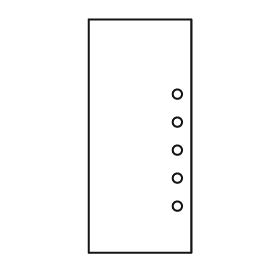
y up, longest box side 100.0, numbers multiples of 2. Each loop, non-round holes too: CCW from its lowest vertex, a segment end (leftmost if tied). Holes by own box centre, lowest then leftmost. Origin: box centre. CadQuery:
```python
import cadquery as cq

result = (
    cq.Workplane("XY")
    .moveTo(-22.0, -50.0)
    .lineTo(22.0, -50.0)
    .lineTo(22.0, 50.0)
    .lineTo(-22.0, 50.0)
    .close()
    .moveTo(16.0, -30.0)
    .circle(2.0)
    .moveTo(16.0, -18.0)
    .circle(2.0)
    .moveTo(16.0, -6.0)
    .circle(2.0)
    .moveTo(16.0, 6.0)
    .circle(2.0)
    .moveTo(16.0, 18.0)
    .circle(2.0)
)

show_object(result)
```